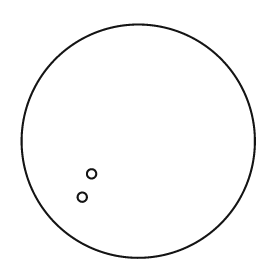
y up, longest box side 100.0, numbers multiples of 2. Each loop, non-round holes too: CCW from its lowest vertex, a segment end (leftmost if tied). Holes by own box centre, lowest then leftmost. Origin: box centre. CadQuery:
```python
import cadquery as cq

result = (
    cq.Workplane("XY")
    .moveTo(0.0, 0.0)
    .circle(50.0)
    .moveTo(-24.0, -24.0)
    .circle(2.0)
    .moveTo(-20.0, -14.0)
    .circle(2.0)
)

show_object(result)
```